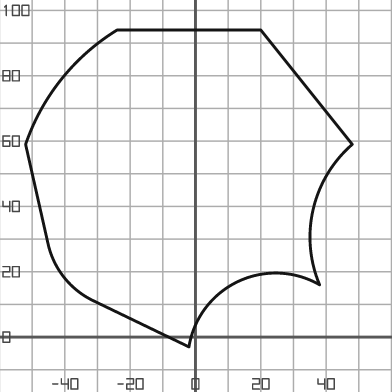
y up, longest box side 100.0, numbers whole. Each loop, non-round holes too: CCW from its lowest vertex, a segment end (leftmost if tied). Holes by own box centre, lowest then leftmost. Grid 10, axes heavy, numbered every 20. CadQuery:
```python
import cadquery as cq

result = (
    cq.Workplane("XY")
    .moveTo(-2.0, -3.0)
    .threePointArc((13.0, 17.0), (38.0, 16.0))
    .threePointArc((36.0, 39.0), (48.0, 59.0))
    .lineTo(20.0, 94.0)
    .lineTo(-24.0, 94.0)
    .threePointArc((-41.0, 79.0), (-52.0, 59.0))
    .lineTo(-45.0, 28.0)
    .threePointArc((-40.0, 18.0), (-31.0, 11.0))
    .close()
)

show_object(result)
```